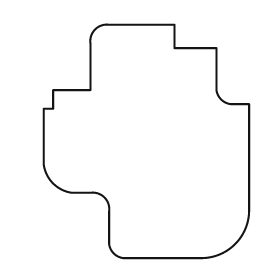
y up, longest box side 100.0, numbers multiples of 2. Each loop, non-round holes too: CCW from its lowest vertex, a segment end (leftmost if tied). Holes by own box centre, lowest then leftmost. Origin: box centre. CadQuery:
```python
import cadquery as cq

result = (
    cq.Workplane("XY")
    .moveTo(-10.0, -50.0)
    .lineTo(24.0, -50.0)
    .threePointArc((38.0, -44.0), (44.0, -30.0))
    .lineTo(44.0, 16.0)
    .lineTo(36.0, 16.0)
    .threePointArc((32.0, 18.0), (30.0, 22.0))
    .lineTo(30.0, 40.0)
    .lineTo(12.0, 40.0)
    .lineTo(12.0, 50.0)
    .lineTo(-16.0, 50.0)
    .threePointArc((-22.0, 48.0), (-24.0, 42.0))
    .lineTo(-24.0, 22.0)
    .lineTo(-40.0, 22.0)
    .lineTo(-40.0, 14.0)
    .lineTo(-44.0, 14.0)
    .lineTo(-44.0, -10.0)
    .threePointArc((-40.0, -18.0), (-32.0, -22.0))
    .lineTo(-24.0, -22.0)
    .threePointArc((-18.0, -24.0), (-16.0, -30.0))
    .lineTo(-16.0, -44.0)
    .threePointArc((-14.0, -48.0), (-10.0, -50.0))
    .close()
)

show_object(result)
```